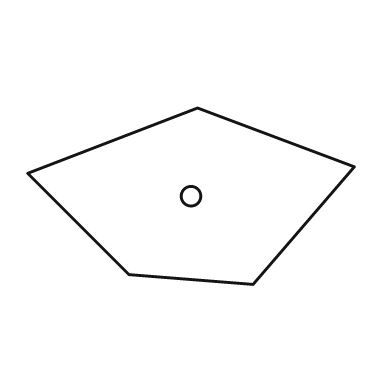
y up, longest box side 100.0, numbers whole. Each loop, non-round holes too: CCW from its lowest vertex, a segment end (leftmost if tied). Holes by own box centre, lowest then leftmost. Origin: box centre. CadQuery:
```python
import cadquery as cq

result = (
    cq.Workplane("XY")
    .moveTo(19.0, -27.0)
    .lineTo(50.0, 9.0)
    .lineTo(2.0, 27.0)
    .lineTo(-50.0, 7.0)
    .lineTo(-19.0, -24.0)
    .close()
    .moveTo(0.0, 0.0)
    .circle(3.0)
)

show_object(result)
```